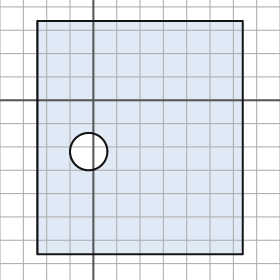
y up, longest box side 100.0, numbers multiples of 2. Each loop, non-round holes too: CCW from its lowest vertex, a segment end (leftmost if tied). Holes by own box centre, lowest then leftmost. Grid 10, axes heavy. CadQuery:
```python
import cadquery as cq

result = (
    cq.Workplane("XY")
    .moveTo(-24.0, -66.0)
    .lineTo(64.0, -66.0)
    .lineTo(64.0, 34.0)
    .lineTo(-24.0, 34.0)
    .close()
    .moveTo(-2.0, -22.0)
    .circle(8.0)
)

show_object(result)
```